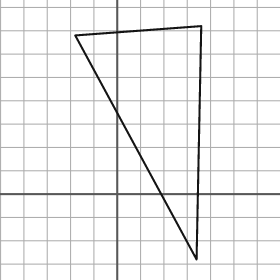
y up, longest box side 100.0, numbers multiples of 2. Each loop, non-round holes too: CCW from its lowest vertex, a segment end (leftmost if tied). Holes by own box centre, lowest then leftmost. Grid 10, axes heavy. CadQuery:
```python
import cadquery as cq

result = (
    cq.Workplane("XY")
    .moveTo(34.0, -28.0)
    .lineTo(36.0, 72.0)
    .lineTo(-18.0, 68.0)
    .close()
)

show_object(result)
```